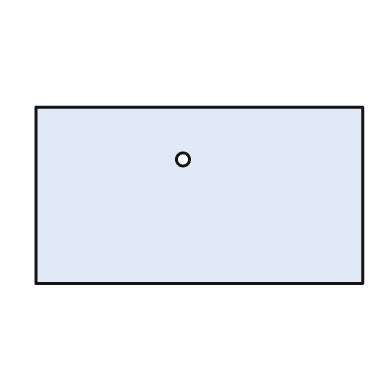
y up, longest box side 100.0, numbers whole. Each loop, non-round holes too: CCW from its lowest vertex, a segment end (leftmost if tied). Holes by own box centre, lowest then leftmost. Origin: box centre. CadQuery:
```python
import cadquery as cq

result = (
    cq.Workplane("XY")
    .moveTo(-50.0, -27.0)
    .lineTo(50.0, -27.0)
    .lineTo(50.0, 27.0)
    .lineTo(-50.0, 27.0)
    .close()
    .moveTo(-5.0, 11.0)
    .circle(2.0)
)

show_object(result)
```